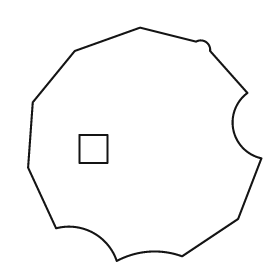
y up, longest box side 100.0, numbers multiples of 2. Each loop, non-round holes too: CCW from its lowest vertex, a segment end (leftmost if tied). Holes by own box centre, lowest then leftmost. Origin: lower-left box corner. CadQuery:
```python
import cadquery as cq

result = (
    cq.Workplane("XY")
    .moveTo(38.0, 0.0)
    .threePointArc((52.0, 4.0), (66.0, 2.0))
    .lineTo(90.0, 18.0)
    .lineTo(100.0, 44.0)
    .threePointArc((88.0, 56.0), (94.0, 72.0))
    .lineTo(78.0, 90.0)
    .threePointArc((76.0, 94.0), (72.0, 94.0))
    .lineTo(48.0, 100.0)
    .lineTo(20.0, 90.0)
    .lineTo(2.0, 68.0)
    .lineTo(0.0, 40.0)
    .lineTo(12.0, 14.0)
    .threePointArc((28.0, 12.0), (38.0, 0.0))
    .close()
    .moveTo(22.0, 42.0)
    .lineTo(34.0, 42.0)
    .lineTo(34.0, 54.0)
    .lineTo(22.0, 54.0)
    .close()
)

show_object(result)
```